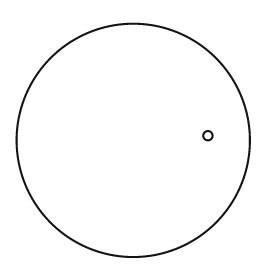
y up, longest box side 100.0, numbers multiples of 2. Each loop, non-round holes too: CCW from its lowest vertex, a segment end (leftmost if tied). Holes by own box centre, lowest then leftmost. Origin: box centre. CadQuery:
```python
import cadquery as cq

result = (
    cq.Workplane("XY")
    .moveTo(0.0, 0.0)
    .circle(50.0)
    .moveTo(32.0, 2.0)
    .circle(2.0)
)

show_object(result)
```